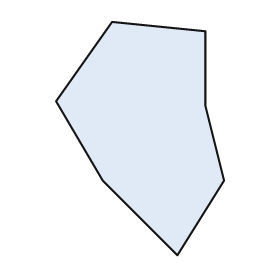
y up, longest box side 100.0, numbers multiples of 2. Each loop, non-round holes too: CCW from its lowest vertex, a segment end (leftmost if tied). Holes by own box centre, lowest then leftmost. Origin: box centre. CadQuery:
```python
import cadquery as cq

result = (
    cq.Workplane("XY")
    .moveTo(16.0, -50.0)
    .lineTo(36.0, -18.0)
    .lineTo(28.0, 14.0)
    .lineTo(28.0, 46.0)
    .lineTo(-12.0, 50.0)
    .lineTo(-36.0, 16.0)
    .lineTo(-16.0, -18.0)
    .close()
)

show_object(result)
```